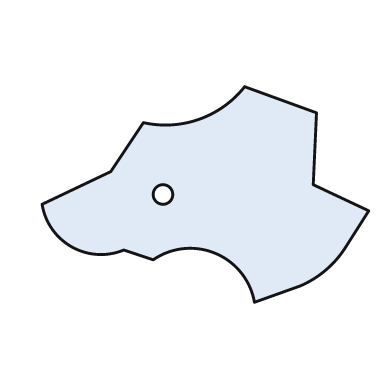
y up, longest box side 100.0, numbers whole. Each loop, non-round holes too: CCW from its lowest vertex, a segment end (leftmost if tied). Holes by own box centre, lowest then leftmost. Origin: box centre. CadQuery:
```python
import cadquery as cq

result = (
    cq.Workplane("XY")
    .moveTo(15.0, -33.0)
    .lineTo(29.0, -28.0)
    .threePointArc((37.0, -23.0), (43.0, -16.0))
    .lineTo(50.0, -5.0)
    .lineTo(33.0, 3.0)
    .lineTo(34.0, 25.0)
    .lineTo(12.0, 33.0)
    .threePointArc((-2.0, 23.0), (-19.0, 22.0))
    .lineTo(-29.0, 7.0)
    .lineTo(-50.0, -3.0)
    .threePointArc((-41.0, -16.0), (-25.0, -17.0))
    .lineTo(-16.0, -20.0)
    .threePointArc((3.0, -18.0), (15.0, -33.0))
    .close()
    .moveTo(-13.0, 0.0)
    .circle(3.0)
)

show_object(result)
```